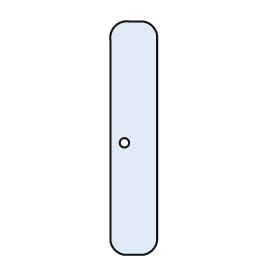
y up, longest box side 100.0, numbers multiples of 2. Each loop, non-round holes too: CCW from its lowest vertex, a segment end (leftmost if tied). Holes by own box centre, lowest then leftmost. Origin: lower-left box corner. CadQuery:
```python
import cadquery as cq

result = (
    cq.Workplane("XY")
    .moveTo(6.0, 0.0)
    .lineTo(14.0, 0.0)
    .threePointArc((18.0, 2.0), (20.0, 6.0))
    .lineTo(20.0, 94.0)
    .threePointArc((18.0, 98.0), (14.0, 100.0))
    .lineTo(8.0, 100.0)
    .threePointArc((2.0, 98.0), (0.0, 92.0))
    .lineTo(0.0, 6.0)
    .threePointArc((2.0, 2.0), (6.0, 0.0))
    .close()
    .moveTo(6.0, 48.0)
    .circle(2.0)
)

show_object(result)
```